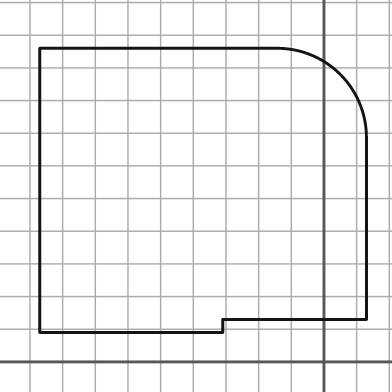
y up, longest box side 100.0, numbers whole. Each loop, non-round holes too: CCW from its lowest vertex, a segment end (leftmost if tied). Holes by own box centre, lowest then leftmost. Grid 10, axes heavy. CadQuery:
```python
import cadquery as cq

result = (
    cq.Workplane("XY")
    .moveTo(-87.0, 9.0)
    .lineTo(-31.0, 9.0)
    .lineTo(-31.0, 13.0)
    .lineTo(13.0, 13.0)
    .lineTo(13.0, 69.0)
    .threePointArc((5.0, 88.0), (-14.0, 96.0))
    .lineTo(-87.0, 96.0)
    .close()
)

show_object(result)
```